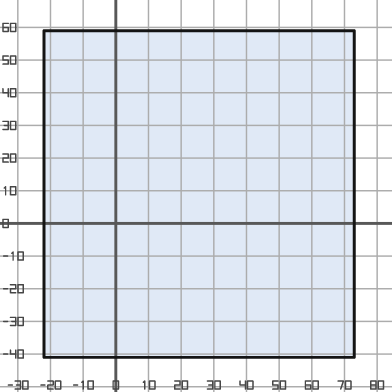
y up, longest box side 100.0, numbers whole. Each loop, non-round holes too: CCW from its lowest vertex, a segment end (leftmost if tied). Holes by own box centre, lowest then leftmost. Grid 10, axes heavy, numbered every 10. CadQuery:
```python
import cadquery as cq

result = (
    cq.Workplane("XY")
    .moveTo(-22.0, -41.0)
    .lineTo(73.0, -41.0)
    .lineTo(73.0, 59.0)
    .lineTo(-22.0, 59.0)
    .close()
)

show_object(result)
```